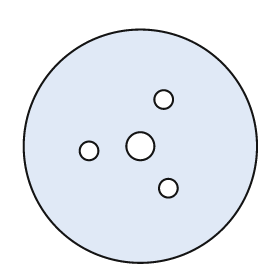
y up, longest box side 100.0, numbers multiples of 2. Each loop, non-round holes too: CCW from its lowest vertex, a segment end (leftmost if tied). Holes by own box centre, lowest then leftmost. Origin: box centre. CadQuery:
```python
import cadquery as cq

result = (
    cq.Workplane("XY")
    .moveTo(0.0, 0.0)
    .circle(50.0)
    .moveTo(12.0, -18.0)
    .circle(4.0)
    .moveTo(-22.0, -2.0)
    .circle(4.0)
    .moveTo(0.0, 0.0)
    .circle(6.0)
    .moveTo(10.0, 20.0)
    .circle(4.0)
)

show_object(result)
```